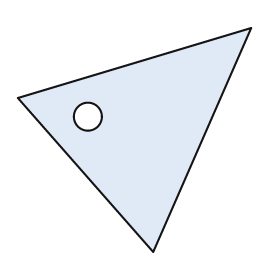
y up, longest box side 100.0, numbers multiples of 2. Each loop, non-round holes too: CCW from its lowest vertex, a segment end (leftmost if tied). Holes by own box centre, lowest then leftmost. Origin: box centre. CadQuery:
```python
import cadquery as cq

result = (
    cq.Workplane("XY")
    .moveTo(8.0, -48.0)
    .lineTo(50.0, 48.0)
    .lineTo(-50.0, 18.0)
    .close()
    .moveTo(-20.0, 10.0)
    .circle(6.0)
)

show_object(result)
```